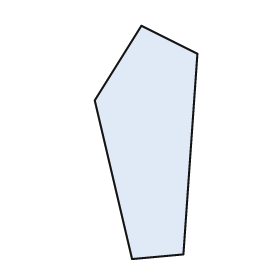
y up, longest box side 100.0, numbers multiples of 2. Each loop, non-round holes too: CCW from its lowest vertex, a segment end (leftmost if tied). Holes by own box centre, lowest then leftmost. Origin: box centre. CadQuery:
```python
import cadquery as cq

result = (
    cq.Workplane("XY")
    .moveTo(-6.0, -50.0)
    .lineTo(16.0, -48.0)
    .lineTo(22.0, 38.0)
    .lineTo(-2.0, 50.0)
    .lineTo(-22.0, 18.0)
    .close()
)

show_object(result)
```